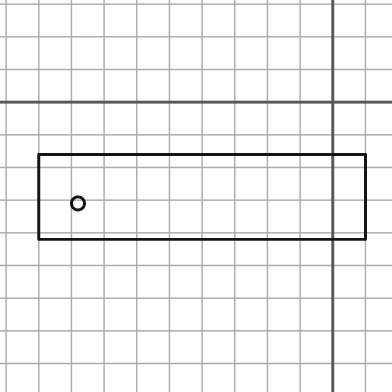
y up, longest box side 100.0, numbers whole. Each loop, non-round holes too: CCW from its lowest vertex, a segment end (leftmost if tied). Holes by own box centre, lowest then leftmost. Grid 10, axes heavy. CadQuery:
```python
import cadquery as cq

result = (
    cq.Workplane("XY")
    .moveTo(-90.0, -42.0)
    .lineTo(10.0, -42.0)
    .lineTo(10.0, -16.0)
    .lineTo(-90.0, -16.0)
    .close()
    .moveTo(-78.0, -31.0)
    .circle(2.0)
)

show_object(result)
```